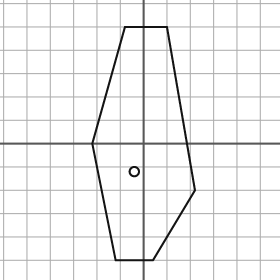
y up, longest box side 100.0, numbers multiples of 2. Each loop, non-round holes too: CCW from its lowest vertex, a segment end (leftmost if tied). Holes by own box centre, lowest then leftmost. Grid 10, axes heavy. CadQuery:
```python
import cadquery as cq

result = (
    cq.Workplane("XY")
    .moveTo(-12.0, -50.0)
    .lineTo(4.0, -50.0)
    .lineTo(22.0, -20.0)
    .lineTo(10.0, 50.0)
    .lineTo(-8.0, 50.0)
    .lineTo(-22.0, 0.0)
    .close()
    .moveTo(-4.0, -12.0)
    .circle(2.0)
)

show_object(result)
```